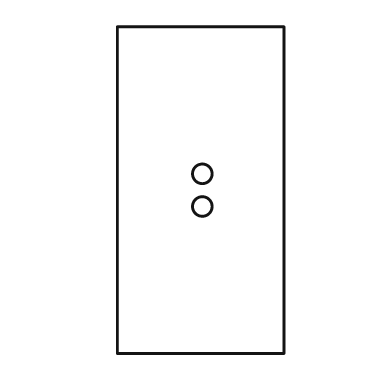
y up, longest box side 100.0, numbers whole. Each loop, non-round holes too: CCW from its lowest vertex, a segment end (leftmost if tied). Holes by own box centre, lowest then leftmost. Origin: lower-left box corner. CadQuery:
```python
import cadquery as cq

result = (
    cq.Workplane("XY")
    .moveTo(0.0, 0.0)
    .lineTo(51.0, 0.0)
    .lineTo(51.0, 100.0)
    .lineTo(0.0, 100.0)
    .close()
    .moveTo(26.0, 45.0)
    .circle(3.0)
    .moveTo(26.0, 55.0)
    .circle(3.0)
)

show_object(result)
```